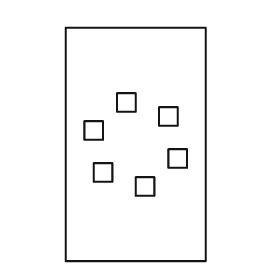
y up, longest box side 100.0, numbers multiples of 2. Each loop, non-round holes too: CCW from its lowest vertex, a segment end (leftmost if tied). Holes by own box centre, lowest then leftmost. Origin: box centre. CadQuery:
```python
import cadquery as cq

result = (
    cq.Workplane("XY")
    .moveTo(-30.0, -50.0)
    .lineTo(30.0, -50.0)
    .lineTo(30.0, 50.0)
    .lineTo(-30.0, 50.0)
    .close()
    .moveTo(0.0, -22.0)
    .lineTo(8.0, -22.0)
    .lineTo(8.0, -14.0)
    .lineTo(0.0, -14.0)
    .close()
    .moveTo(-18.0, -16.0)
    .lineTo(-10.0, -16.0)
    .lineTo(-10.0, -8.0)
    .lineTo(-18.0, -8.0)
    .close()
    .moveTo(14.0, -10.0)
    .lineTo(22.0, -10.0)
    .lineTo(22.0, -2.0)
    .lineTo(14.0, -2.0)
    .close()
    .moveTo(-22.0, 2.0)
    .lineTo(-14.0, 2.0)
    .lineTo(-14.0, 10.0)
    .lineTo(-22.0, 10.0)
    .close()
    .moveTo(10.0, 8.0)
    .lineTo(18.0, 8.0)
    .lineTo(18.0, 16.0)
    .lineTo(10.0, 16.0)
    .close()
    .moveTo(-8.0, 14.0)
    .lineTo(0.0, 14.0)
    .lineTo(0.0, 22.0)
    .lineTo(-8.0, 22.0)
    .close()
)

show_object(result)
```